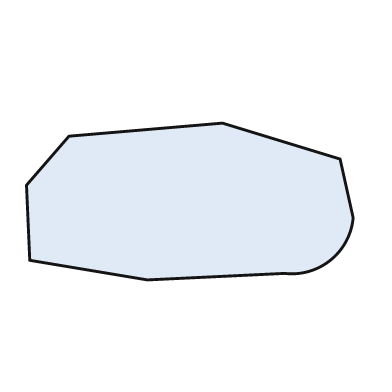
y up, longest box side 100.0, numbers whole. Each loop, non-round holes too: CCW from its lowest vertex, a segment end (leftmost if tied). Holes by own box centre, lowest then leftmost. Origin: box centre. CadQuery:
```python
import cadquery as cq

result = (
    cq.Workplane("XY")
    .moveTo(-13.0, -24.0)
    .lineTo(29.0, -22.0)
    .threePointArc((43.0, -18.0), (50.0, -5.0))
    .lineTo(46.0, 13.0)
    .lineTo(10.0, 24.0)
    .lineTo(-37.0, 20.0)
    .lineTo(-50.0, 5.0)
    .lineTo(-49.0, -18.0)
    .close()
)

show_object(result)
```